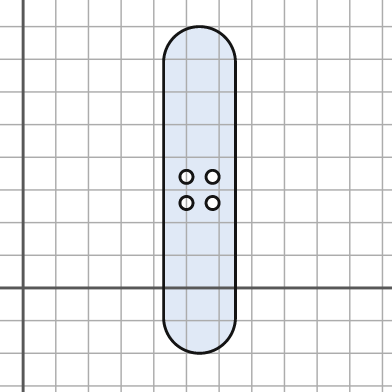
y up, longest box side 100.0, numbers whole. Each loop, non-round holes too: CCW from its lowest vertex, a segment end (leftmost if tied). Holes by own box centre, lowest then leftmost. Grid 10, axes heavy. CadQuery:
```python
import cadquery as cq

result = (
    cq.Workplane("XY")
    .moveTo(43.0, -9.0)
    .threePointArc((54.0, -20.0), (65.0, -9.0))
    .lineTo(65.0, 69.0)
    .threePointArc((54.0, 80.0), (43.0, 69.0))
    .close()
    .moveTo(50.0, 26.0)
    .circle(2.0)
    .moveTo(58.0, 26.0)
    .circle(2.0)
    .moveTo(50.0, 34.0)
    .circle(2.0)
    .moveTo(58.0, 34.0)
    .circle(2.0)
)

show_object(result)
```